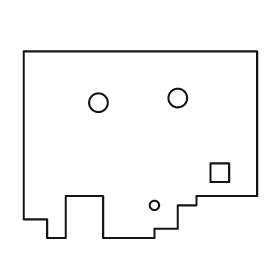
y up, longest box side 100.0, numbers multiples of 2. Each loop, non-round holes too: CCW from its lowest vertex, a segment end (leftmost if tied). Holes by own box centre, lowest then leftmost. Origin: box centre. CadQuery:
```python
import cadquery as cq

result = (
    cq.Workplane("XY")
    .moveTo(-40.0, -40.0)
    .lineTo(-32.0, -40.0)
    .lineTo(-32.0, -22.0)
    .lineTo(-16.0, -22.0)
    .lineTo(-16.0, -40.0)
    .lineTo(6.0, -40.0)
    .lineTo(6.0, -36.0)
    .lineTo(16.0, -36.0)
    .lineTo(16.0, -26.0)
    .lineTo(24.0, -26.0)
    .lineTo(24.0, -22.0)
    .lineTo(50.0, -22.0)
    .lineTo(50.0, 40.0)
    .lineTo(-50.0, 40.0)
    .lineTo(-50.0, -32.0)
    .lineTo(-40.0, -32.0)
    .close()
    .moveTo(6.0, -26.0)
    .circle(2.0)
    .moveTo(30.0, -16.0)
    .lineTo(38.0, -16.0)
    .lineTo(38.0, -8.0)
    .lineTo(30.0, -8.0)
    .close()
    .moveTo(-18.0, 18.0)
    .circle(4.0)
    .moveTo(16.0, 20.0)
    .circle(4.0)
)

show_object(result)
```